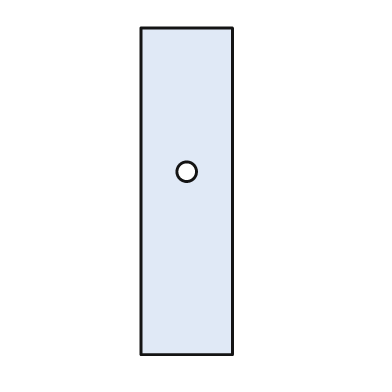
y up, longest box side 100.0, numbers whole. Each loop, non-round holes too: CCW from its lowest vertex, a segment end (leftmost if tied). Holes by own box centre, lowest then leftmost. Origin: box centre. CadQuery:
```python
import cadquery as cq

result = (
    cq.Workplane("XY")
    .moveTo(-14.0, -50.0)
    .lineTo(14.0, -50.0)
    .lineTo(14.0, 50.0)
    .lineTo(-14.0, 50.0)
    .close()
    .moveTo(0.0, 6.0)
    .circle(3.0)
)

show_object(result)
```